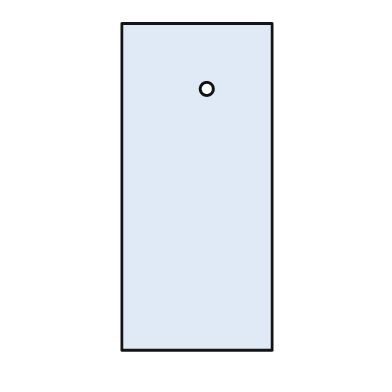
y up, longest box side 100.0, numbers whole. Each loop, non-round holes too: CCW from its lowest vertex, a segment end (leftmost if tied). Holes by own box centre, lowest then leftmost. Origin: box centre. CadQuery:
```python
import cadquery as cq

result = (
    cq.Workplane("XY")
    .moveTo(-23.0, -50.0)
    .lineTo(23.0, -50.0)
    .lineTo(23.0, 50.0)
    .lineTo(-23.0, 50.0)
    .close()
    .moveTo(3.0, 30.0)
    .circle(2.0)
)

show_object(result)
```